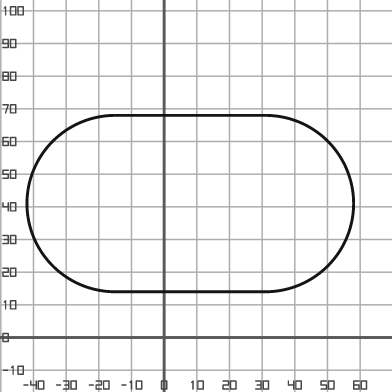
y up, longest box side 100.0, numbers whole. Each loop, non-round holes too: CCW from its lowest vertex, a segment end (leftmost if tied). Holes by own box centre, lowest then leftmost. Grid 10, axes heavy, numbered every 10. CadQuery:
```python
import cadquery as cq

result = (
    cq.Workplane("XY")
    .moveTo(-15.0, 14.0)
    .lineTo(31.0, 14.0)
    .threePointArc((58.0, 41.0), (31.0, 68.0))
    .lineTo(-15.0, 68.0)
    .threePointArc((-42.0, 41.0), (-15.0, 14.0))
    .close()
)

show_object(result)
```